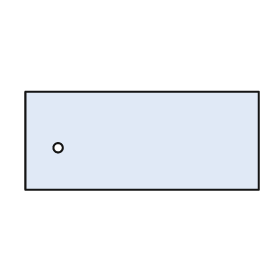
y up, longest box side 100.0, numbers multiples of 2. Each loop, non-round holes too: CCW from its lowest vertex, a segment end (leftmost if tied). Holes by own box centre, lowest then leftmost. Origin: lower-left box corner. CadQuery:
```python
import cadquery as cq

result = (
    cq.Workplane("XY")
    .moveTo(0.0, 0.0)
    .lineTo(100.0, 0.0)
    .lineTo(100.0, 42.0)
    .lineTo(0.0, 42.0)
    .close()
    .moveTo(14.0, 18.0)
    .circle(2.0)
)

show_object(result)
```